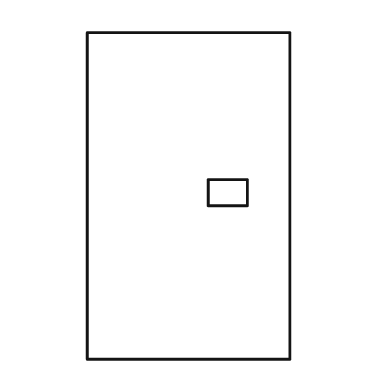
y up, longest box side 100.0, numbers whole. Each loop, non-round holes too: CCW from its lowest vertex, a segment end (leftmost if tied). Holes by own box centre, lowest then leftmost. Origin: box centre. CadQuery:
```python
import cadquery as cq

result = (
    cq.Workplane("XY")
    .moveTo(-31.0, -50.0)
    .lineTo(31.0, -50.0)
    .lineTo(31.0, 50.0)
    .lineTo(-31.0, 50.0)
    .close()
    .moveTo(6.0, -3.0)
    .lineTo(18.0, -3.0)
    .lineTo(18.0, 5.0)
    .lineTo(6.0, 5.0)
    .close()
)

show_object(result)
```